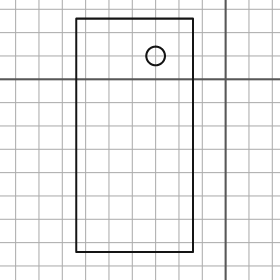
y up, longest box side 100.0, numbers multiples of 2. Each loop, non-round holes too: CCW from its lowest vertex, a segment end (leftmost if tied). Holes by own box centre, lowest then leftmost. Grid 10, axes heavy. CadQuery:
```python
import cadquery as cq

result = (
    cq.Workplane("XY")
    .moveTo(-64.0, -74.0)
    .lineTo(-14.0, -74.0)
    .lineTo(-14.0, 26.0)
    .lineTo(-64.0, 26.0)
    .close()
    .moveTo(-30.0, 10.0)
    .circle(4.0)
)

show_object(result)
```